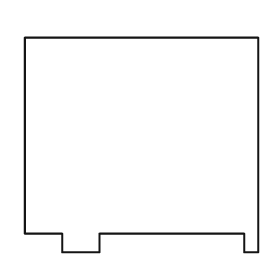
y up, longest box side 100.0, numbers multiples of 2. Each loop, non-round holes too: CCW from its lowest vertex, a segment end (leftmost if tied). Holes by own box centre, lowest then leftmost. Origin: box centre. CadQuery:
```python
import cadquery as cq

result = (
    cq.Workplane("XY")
    .moveTo(-34.0, -46.0)
    .lineTo(-18.0, -46.0)
    .lineTo(-18.0, -38.0)
    .lineTo(44.0, -38.0)
    .lineTo(44.0, -46.0)
    .lineTo(50.0, -46.0)
    .lineTo(50.0, 46.0)
    .lineTo(-50.0, 46.0)
    .lineTo(-50.0, -38.0)
    .lineTo(-34.0, -38.0)
    .close()
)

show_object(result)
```